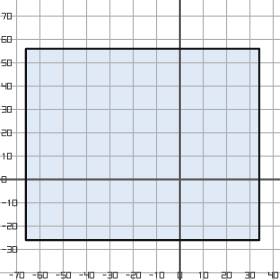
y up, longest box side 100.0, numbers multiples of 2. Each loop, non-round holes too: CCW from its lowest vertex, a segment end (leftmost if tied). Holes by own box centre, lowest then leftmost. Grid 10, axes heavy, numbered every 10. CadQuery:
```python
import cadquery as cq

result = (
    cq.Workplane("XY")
    .moveTo(-66.0, -26.0)
    .lineTo(34.0, -26.0)
    .lineTo(34.0, 56.0)
    .lineTo(-66.0, 56.0)
    .close()
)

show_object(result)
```